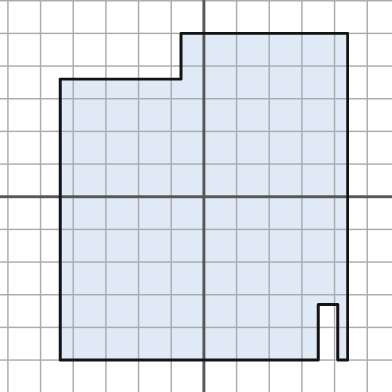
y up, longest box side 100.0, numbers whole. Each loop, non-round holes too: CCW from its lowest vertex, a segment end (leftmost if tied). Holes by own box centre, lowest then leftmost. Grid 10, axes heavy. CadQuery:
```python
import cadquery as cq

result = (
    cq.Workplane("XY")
    .moveTo(-44.0, -50.0)
    .lineTo(35.0, -50.0)
    .lineTo(35.0, -33.0)
    .lineTo(41.0, -33.0)
    .lineTo(41.0, -50.0)
    .lineTo(44.0, -50.0)
    .lineTo(44.0, 50.0)
    .lineTo(-7.0, 50.0)
    .lineTo(-7.0, 36.0)
    .lineTo(-44.0, 36.0)
    .close()
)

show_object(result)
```